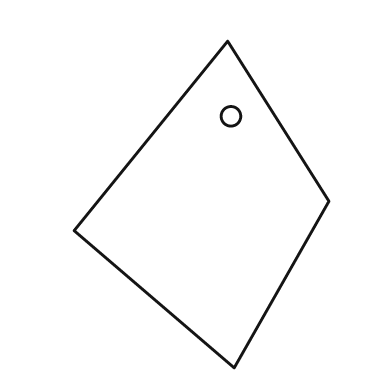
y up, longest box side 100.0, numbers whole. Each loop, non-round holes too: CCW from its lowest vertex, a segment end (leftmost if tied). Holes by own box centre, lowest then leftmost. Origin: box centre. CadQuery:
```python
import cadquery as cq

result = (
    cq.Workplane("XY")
    .moveTo(10.0, -50.0)
    .lineTo(39.0, 1.0)
    .lineTo(8.0, 50.0)
    .lineTo(-39.0, -8.0)
    .close()
    .moveTo(9.0, 27.0)
    .circle(3.0)
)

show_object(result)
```